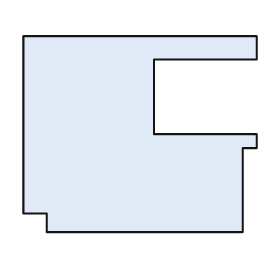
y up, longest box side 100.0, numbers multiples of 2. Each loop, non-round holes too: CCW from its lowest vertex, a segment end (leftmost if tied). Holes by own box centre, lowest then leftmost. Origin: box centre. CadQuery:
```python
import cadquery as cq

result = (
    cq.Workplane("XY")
    .moveTo(-40.0, -42.0)
    .lineTo(44.0, -42.0)
    .lineTo(44.0, -6.0)
    .lineTo(50.0, -6.0)
    .lineTo(50.0, 0.0)
    .lineTo(6.0, 0.0)
    .lineTo(6.0, 32.0)
    .lineTo(50.0, 32.0)
    .lineTo(50.0, 42.0)
    .lineTo(-50.0, 42.0)
    .lineTo(-50.0, -34.0)
    .lineTo(-40.0, -34.0)
    .close()
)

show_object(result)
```